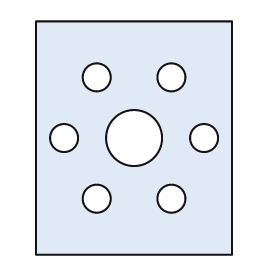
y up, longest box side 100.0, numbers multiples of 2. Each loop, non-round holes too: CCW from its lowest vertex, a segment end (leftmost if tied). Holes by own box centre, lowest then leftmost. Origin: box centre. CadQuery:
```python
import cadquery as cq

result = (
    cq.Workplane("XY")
    .moveTo(-42.0, -50.0)
    .lineTo(42.0, -50.0)
    .lineTo(42.0, 50.0)
    .lineTo(-42.0, 50.0)
    .close()
    .moveTo(-16.0, -26.0)
    .circle(6.0)
    .moveTo(16.0, -26.0)
    .circle(6.0)
    .moveTo(-30.0, 0.0)
    .circle(6.0)
    .moveTo(0.0, 0.0)
    .circle(12.0)
    .moveTo(30.0, 0.0)
    .circle(6.0)
    .moveTo(-16.0, 26.0)
    .circle(6.0)
    .moveTo(16.0, 26.0)
    .circle(6.0)
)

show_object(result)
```